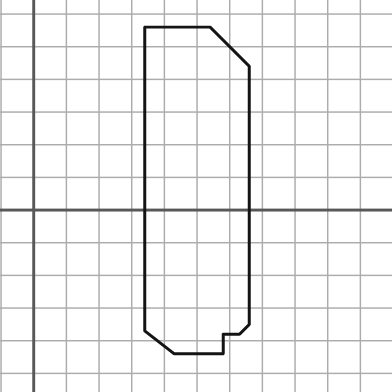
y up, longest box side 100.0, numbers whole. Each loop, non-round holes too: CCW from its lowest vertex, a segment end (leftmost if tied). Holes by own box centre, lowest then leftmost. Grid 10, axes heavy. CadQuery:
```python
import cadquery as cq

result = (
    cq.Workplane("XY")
    .moveTo(43.0, -44.0)
    .lineTo(58.0, -44.0)
    .lineTo(58.0, -38.0)
    .lineTo(63.0, -38.0)
    .lineTo(66.0, -35.0)
    .lineTo(66.0, 44.0)
    .lineTo(54.0, 56.0)
    .lineTo(34.0, 56.0)
    .lineTo(34.0, -37.0)
    .close()
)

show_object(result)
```